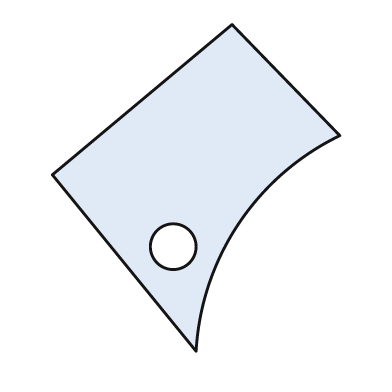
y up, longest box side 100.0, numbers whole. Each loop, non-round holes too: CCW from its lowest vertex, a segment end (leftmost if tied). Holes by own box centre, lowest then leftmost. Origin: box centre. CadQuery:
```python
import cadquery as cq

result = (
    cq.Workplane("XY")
    .moveTo(0.0, -50.0)
    .threePointArc((13.0, -11.0), (44.0, 16.0))
    .lineTo(11.0, 50.0)
    .lineTo(-44.0, 4.0)
    .close()
    .moveTo(-7.0, -18.0)
    .circle(7.0)
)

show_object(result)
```